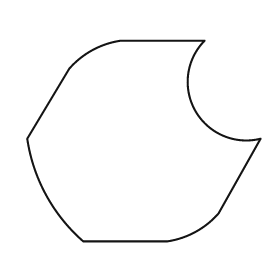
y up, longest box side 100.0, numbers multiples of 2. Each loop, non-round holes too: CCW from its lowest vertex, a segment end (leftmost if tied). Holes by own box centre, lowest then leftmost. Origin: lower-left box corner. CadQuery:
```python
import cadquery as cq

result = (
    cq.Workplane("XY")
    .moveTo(24.0, 0.0)
    .lineTo(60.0, 0.0)
    .threePointArc((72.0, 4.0), (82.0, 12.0))
    .lineTo(100.0, 44.0)
    .threePointArc((72.0, 56.0), (76.0, 86.0))
    .lineTo(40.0, 86.0)
    .threePointArc((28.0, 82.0), (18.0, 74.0))
    .lineTo(0.0, 44.0)
    .threePointArc((8.0, 20.0), (24.0, 0.0))
    .close()
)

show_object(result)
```